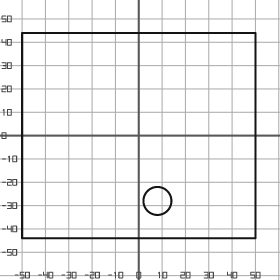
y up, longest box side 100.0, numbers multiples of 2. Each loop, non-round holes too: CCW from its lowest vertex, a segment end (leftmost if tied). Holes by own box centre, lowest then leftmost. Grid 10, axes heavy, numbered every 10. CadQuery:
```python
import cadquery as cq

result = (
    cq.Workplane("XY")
    .moveTo(-50.0, -44.0)
    .lineTo(50.0, -44.0)
    .lineTo(50.0, 44.0)
    .lineTo(-50.0, 44.0)
    .close()
    .moveTo(8.0, -28.0)
    .circle(6.0)
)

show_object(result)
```